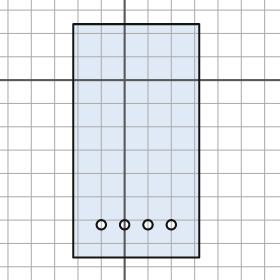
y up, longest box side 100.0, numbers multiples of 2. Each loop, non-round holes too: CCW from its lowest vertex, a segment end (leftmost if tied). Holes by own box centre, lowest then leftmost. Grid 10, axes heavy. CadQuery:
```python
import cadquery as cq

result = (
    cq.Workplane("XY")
    .moveTo(-22.0, -76.0)
    .lineTo(32.0, -76.0)
    .lineTo(32.0, 24.0)
    .lineTo(-22.0, 24.0)
    .close()
    .moveTo(-10.0, -62.0)
    .circle(2.0)
    .moveTo(0.0, -62.0)
    .circle(2.0)
    .moveTo(10.0, -62.0)
    .circle(2.0)
    .moveTo(20.0, -62.0)
    .circle(2.0)
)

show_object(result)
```